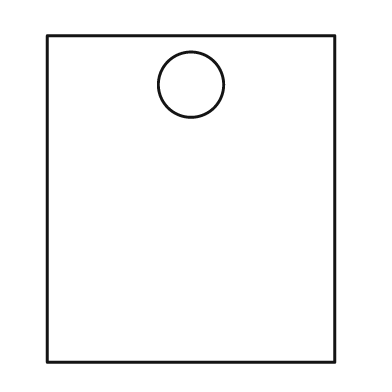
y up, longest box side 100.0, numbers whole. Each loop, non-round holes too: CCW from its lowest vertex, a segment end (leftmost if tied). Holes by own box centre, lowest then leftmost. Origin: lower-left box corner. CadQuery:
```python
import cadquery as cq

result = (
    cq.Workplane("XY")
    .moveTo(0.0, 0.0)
    .lineTo(88.0, 0.0)
    .lineTo(88.0, 100.0)
    .lineTo(0.0, 100.0)
    .close()
    .moveTo(44.0, 85.0)
    .circle(10.0)
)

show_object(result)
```